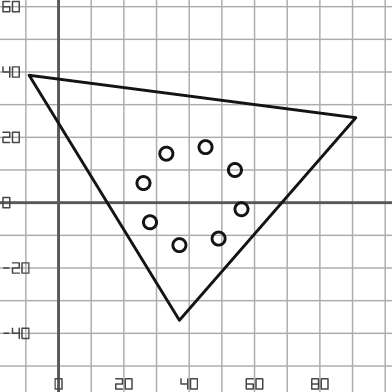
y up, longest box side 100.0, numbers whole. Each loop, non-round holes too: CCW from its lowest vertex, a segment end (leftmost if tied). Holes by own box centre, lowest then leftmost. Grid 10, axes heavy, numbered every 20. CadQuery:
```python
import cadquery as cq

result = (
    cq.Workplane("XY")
    .moveTo(37.0, -36.0)
    .lineTo(91.0, 26.0)
    .lineTo(-9.0, 39.0)
    .close()
    .moveTo(37.0, -13.0)
    .circle(2.0)
    .moveTo(49.0, -11.0)
    .circle(2.0)
    .moveTo(28.0, -6.0)
    .circle(2.0)
    .moveTo(56.0, -2.0)
    .circle(2.0)
    .moveTo(26.0, 6.0)
    .circle(2.0)
    .moveTo(54.0, 10.0)
    .circle(2.0)
    .moveTo(33.0, 15.0)
    .circle(2.0)
    .moveTo(45.0, 17.0)
    .circle(2.0)
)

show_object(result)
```